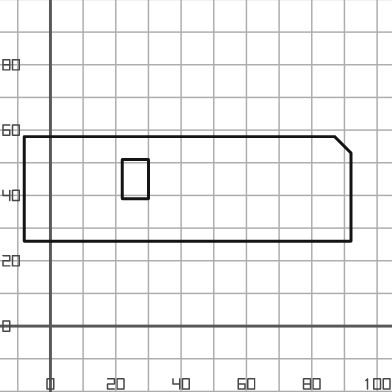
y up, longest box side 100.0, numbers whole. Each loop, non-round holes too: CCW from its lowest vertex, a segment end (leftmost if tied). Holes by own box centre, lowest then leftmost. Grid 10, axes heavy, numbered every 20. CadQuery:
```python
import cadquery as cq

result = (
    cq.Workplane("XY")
    .moveTo(-8.0, 26.0)
    .lineTo(92.0, 26.0)
    .lineTo(92.0, 53.0)
    .lineTo(87.0, 58.0)
    .lineTo(-8.0, 58.0)
    .close()
    .moveTo(22.0, 39.0)
    .lineTo(30.0, 39.0)
    .lineTo(30.0, 51.0)
    .lineTo(22.0, 51.0)
    .close()
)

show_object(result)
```